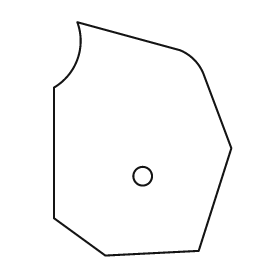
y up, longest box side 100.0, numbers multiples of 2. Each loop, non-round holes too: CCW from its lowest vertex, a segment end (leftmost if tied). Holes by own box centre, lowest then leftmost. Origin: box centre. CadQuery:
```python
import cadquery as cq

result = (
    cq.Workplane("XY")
    .moveTo(-16.0, -50.0)
    .lineTo(24.0, -48.0)
    .lineTo(38.0, -4.0)
    .lineTo(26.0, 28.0)
    .threePointArc((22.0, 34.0), (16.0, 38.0))
    .lineTo(-28.0, 50.0)
    .threePointArc((-28.0, 34.0), (-38.0, 22.0))
    .lineTo(-38.0, -34.0)
    .close()
    .moveTo(0.0, -16.0)
    .circle(4.0)
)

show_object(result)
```